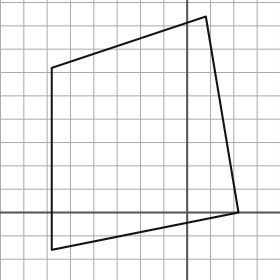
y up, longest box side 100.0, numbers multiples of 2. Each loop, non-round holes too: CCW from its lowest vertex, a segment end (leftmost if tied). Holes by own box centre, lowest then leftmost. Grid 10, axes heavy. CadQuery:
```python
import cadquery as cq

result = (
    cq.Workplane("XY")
    .moveTo(-58.0, -16.0)
    .lineTo(22.0, 0.0)
    .lineTo(8.0, 84.0)
    .lineTo(-58.0, 62.0)
    .close()
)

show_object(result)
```